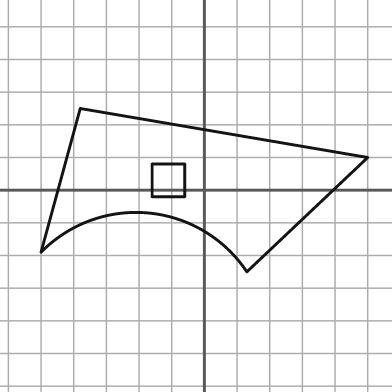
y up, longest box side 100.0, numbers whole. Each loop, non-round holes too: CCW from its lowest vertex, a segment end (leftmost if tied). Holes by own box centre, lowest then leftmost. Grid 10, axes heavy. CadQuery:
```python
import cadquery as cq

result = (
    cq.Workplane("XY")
    .moveTo(13.0, -25.0)
    .lineTo(50.0, 10.0)
    .lineTo(-38.0, 25.0)
    .lineTo(-50.0, -19.0)
    .threePointArc((-17.0, -7.0), (13.0, -25.0))
    .close()
    .moveTo(-16.0, -2.0)
    .lineTo(-6.0, -2.0)
    .lineTo(-6.0, 8.0)
    .lineTo(-16.0, 8.0)
    .close()
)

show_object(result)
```